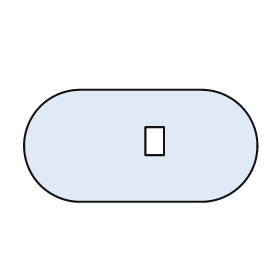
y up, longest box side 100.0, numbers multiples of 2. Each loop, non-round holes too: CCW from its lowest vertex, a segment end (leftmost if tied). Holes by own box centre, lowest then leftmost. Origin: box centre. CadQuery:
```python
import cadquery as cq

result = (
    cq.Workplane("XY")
    .moveTo(-26.0, -24.0)
    .lineTo(26.0, -24.0)
    .threePointArc((50.0, 0.0), (26.0, 24.0))
    .lineTo(-26.0, 24.0)
    .threePointArc((-50.0, 0.0), (-26.0, -24.0))
    .close()
    .moveTo(2.0, -4.0)
    .lineTo(10.0, -4.0)
    .lineTo(10.0, 8.0)
    .lineTo(2.0, 8.0)
    .close()
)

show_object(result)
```